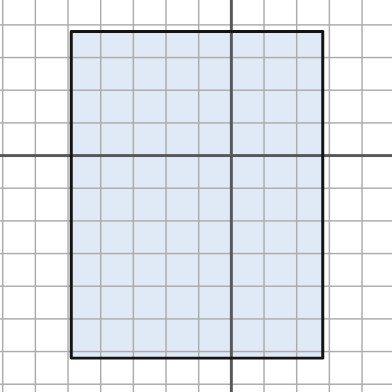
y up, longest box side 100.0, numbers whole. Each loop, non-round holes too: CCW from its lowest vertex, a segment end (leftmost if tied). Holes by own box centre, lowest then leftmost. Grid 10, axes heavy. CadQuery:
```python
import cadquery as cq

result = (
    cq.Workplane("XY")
    .moveTo(-49.0, -62.0)
    .lineTo(28.0, -62.0)
    .lineTo(28.0, 38.0)
    .lineTo(-49.0, 38.0)
    .close()
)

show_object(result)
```